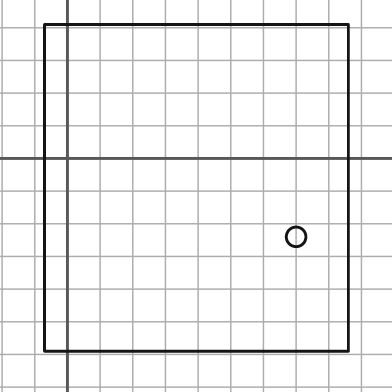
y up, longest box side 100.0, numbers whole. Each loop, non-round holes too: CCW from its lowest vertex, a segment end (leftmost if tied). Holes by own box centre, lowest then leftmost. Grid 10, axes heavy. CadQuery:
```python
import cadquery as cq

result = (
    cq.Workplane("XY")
    .moveTo(-7.0, -59.0)
    .lineTo(86.0, -59.0)
    .lineTo(86.0, 41.0)
    .lineTo(-7.0, 41.0)
    .close()
    .moveTo(70.0, -24.0)
    .circle(3.0)
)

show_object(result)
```